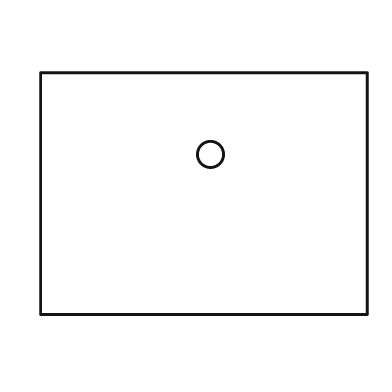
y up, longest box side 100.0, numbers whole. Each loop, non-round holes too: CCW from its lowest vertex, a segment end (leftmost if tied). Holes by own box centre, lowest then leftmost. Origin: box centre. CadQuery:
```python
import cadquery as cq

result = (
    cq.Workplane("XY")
    .moveTo(-50.0, -37.0)
    .lineTo(50.0, -37.0)
    .lineTo(50.0, 37.0)
    .lineTo(-50.0, 37.0)
    .close()
    .moveTo(2.0, 12.0)
    .circle(4.0)
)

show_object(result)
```